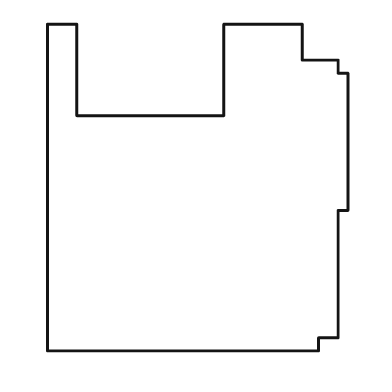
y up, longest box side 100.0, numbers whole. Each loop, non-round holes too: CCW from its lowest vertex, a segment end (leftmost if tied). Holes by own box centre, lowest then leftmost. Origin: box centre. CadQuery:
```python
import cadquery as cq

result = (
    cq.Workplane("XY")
    .moveTo(-46.0, -50.0)
    .lineTo(37.0, -50.0)
    .lineTo(37.0, -46.0)
    .lineTo(43.0, -46.0)
    .lineTo(43.0, -7.0)
    .lineTo(46.0, -7.0)
    .lineTo(46.0, 35.0)
    .lineTo(43.0, 35.0)
    .lineTo(43.0, 39.0)
    .lineTo(32.0, 39.0)
    .lineTo(32.0, 50.0)
    .lineTo(8.0, 50.0)
    .lineTo(8.0, 22.0)
    .lineTo(-37.0, 22.0)
    .lineTo(-37.0, 50.0)
    .lineTo(-46.0, 50.0)
    .close()
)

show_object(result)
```